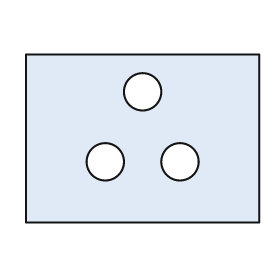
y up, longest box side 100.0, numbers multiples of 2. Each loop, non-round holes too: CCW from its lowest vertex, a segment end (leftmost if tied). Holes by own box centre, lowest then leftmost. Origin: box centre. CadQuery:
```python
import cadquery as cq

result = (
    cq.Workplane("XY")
    .moveTo(-50.0, -36.0)
    .lineTo(50.0, -36.0)
    .lineTo(50.0, 36.0)
    .lineTo(-50.0, 36.0)
    .close()
    .moveTo(-16.0, -10.0)
    .circle(8.0)
    .moveTo(16.0, -10.0)
    .circle(8.0)
    .moveTo(0.0, 20.0)
    .circle(8.0)
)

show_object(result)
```